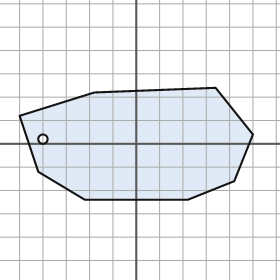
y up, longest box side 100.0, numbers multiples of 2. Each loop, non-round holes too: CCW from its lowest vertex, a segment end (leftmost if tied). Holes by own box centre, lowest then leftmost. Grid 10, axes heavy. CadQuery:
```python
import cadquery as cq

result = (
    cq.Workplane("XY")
    .moveTo(-22.0, -24.0)
    .lineTo(22.0, -24.0)
    .lineTo(42.0, -16.0)
    .lineTo(50.0, 4.0)
    .lineTo(34.0, 24.0)
    .lineTo(-18.0, 22.0)
    .lineTo(-50.0, 12.0)
    .lineTo(-42.0, -12.0)
    .close()
    .moveTo(-40.0, 2.0)
    .circle(2.0)
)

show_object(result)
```